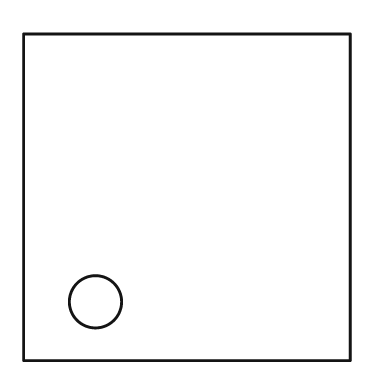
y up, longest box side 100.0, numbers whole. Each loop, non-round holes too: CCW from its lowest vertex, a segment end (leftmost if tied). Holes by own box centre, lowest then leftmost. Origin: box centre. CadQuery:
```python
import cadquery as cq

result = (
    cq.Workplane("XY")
    .moveTo(-50.0, -50.0)
    .lineTo(50.0, -50.0)
    .lineTo(50.0, 50.0)
    .lineTo(-50.0, 50.0)
    .close()
    .moveTo(-28.0, -32.0)
    .circle(8.0)
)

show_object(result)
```